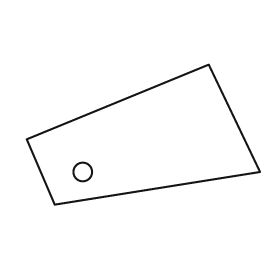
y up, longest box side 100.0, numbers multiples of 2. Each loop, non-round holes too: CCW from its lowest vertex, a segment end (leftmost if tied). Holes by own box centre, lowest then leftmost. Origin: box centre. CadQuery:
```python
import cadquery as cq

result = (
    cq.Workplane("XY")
    .moveTo(-38.0, -30.0)
    .lineTo(50.0, -16.0)
    .lineTo(28.0, 30.0)
    .lineTo(-50.0, -2.0)
    .close()
    .moveTo(-26.0, -16.0)
    .circle(4.0)
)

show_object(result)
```